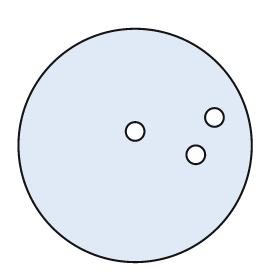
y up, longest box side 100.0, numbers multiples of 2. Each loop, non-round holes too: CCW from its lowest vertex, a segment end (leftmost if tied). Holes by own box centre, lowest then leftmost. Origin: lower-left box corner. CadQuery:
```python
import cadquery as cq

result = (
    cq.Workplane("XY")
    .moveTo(50.0, 50.0)
    .circle(50.0)
    .moveTo(76.0, 46.0)
    .circle(4.0)
    .moveTo(50.0, 56.0)
    .circle(4.0)
    .moveTo(84.0, 62.0)
    .circle(4.0)
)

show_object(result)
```